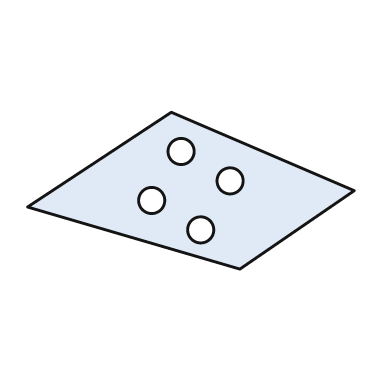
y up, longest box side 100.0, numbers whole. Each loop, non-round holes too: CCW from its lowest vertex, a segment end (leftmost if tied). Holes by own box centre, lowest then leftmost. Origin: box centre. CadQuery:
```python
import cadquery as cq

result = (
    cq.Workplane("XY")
    .moveTo(15.0, -24.0)
    .lineTo(50.0, 0.0)
    .lineTo(-6.0, 24.0)
    .lineTo(-50.0, -5.0)
    .close()
    .moveTo(3.0, -12.0)
    .circle(4.0)
    .moveTo(-12.0, -3.0)
    .circle(4.0)
    .moveTo(12.0, 3.0)
    .circle(4.0)
    .moveTo(-3.0, 12.0)
    .circle(4.0)
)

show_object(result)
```